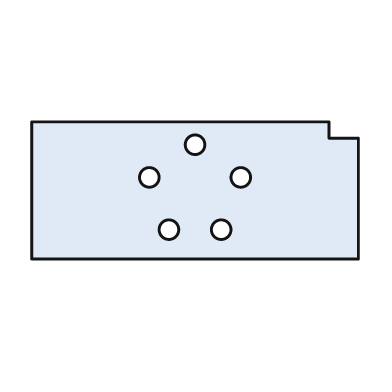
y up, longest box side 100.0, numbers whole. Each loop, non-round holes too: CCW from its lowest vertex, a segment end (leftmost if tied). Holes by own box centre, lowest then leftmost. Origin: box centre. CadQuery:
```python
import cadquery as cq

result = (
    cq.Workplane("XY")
    .moveTo(-50.0, -21.0)
    .lineTo(50.0, -21.0)
    .lineTo(50.0, 16.0)
    .lineTo(41.0, 16.0)
    .lineTo(41.0, 21.0)
    .lineTo(-50.0, 21.0)
    .close()
    .moveTo(-8.0, -12.0)
    .circle(3.0)
    .moveTo(8.0, -12.0)
    .circle(3.0)
    .moveTo(-14.0, 4.0)
    .circle(3.0)
    .moveTo(14.0, 4.0)
    .circle(3.0)
    .moveTo(0.0, 14.0)
    .circle(3.0)
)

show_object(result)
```